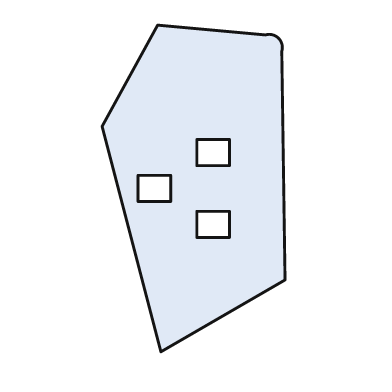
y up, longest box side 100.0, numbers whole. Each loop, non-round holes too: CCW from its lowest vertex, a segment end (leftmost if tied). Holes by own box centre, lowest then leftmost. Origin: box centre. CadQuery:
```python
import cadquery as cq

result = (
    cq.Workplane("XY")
    .moveTo(-10.0, -50.0)
    .lineTo(28.0, -28.0)
    .lineTo(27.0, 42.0)
    .threePointArc((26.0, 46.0), (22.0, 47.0))
    .lineTo(-11.0, 50.0)
    .lineTo(-28.0, 19.0)
    .close()
    .moveTo(1.0, -15.0)
    .lineTo(11.0, -15.0)
    .lineTo(11.0, -7.0)
    .lineTo(1.0, -7.0)
    .close()
    .moveTo(-17.0, -4.0)
    .lineTo(-7.0, -4.0)
    .lineTo(-7.0, 4.0)
    .lineTo(-17.0, 4.0)
    .close()
    .moveTo(1.0, 7.0)
    .lineTo(11.0, 7.0)
    .lineTo(11.0, 15.0)
    .lineTo(1.0, 15.0)
    .close()
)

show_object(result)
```